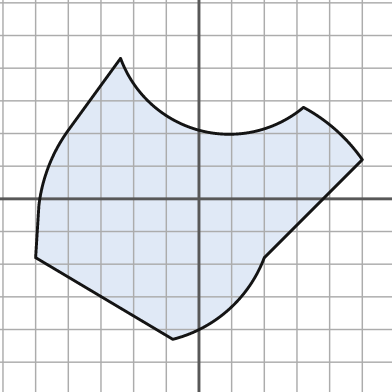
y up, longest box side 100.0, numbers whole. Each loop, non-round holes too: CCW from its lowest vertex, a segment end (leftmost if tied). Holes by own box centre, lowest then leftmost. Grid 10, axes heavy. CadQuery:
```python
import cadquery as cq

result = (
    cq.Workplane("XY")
    .moveTo(-8.0, -43.0)
    .threePointArc((9.0, -34.0), (20.0, -18.0))
    .lineTo(50.0, 12.0)
    .threePointArc((42.0, 21.0), (32.0, 28.0))
    .threePointArc((0.0, 21.0), (-24.0, 43.0))
    .lineTo(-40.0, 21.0)
    .threePointArc((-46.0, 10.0), (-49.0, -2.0))
    .lineTo(-50.0, -18.0)
    .close()
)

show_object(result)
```